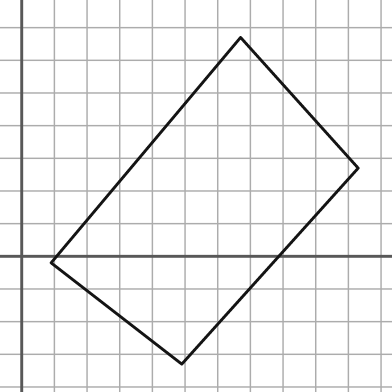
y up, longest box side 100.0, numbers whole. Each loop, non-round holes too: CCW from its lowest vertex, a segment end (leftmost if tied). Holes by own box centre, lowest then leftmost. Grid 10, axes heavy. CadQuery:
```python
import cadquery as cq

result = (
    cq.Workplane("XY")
    .moveTo(49.0, -33.0)
    .lineTo(103.0, 27.0)
    .lineTo(67.0, 67.0)
    .lineTo(9.0, -2.0)
    .close()
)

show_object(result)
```